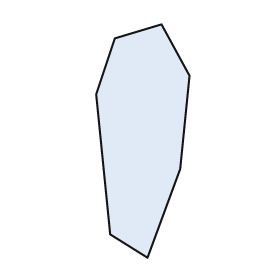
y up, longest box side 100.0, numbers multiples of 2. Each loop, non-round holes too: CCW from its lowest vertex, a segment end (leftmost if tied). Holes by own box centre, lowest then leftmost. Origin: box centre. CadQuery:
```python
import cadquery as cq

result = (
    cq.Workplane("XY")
    .moveTo(2.0, -50.0)
    .lineTo(16.0, -12.0)
    .lineTo(20.0, 28.0)
    .lineTo(8.0, 50.0)
    .lineTo(-12.0, 44.0)
    .lineTo(-20.0, 20.0)
    .lineTo(-14.0, -40.0)
    .close()
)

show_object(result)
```